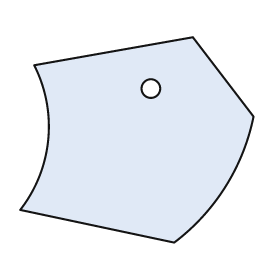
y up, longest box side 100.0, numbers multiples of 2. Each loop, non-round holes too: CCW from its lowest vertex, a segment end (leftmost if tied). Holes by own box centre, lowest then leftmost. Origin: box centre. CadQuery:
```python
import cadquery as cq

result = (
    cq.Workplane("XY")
    .moveTo(16.0, -44.0)
    .threePointArc((38.0, -20.0), (50.0, 10.0))
    .lineTo(24.0, 44.0)
    .lineTo(-44.0, 32.0)
    .threePointArc((-38.0, 0.0), (-50.0, -30.0))
    .close()
    .moveTo(6.0, 22.0)
    .circle(4.0)
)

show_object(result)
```